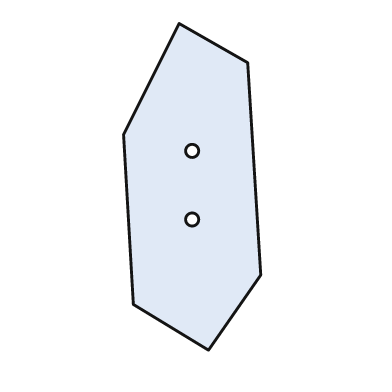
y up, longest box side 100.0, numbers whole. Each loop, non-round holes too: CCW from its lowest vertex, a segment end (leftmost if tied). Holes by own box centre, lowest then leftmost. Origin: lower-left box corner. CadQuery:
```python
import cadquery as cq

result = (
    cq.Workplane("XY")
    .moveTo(26.0, 0.0)
    .lineTo(42.0, 23.0)
    .lineTo(38.0, 88.0)
    .lineTo(17.0, 100.0)
    .lineTo(0.0, 66.0)
    .lineTo(3.0, 14.0)
    .close()
    .moveTo(21.0, 40.0)
    .circle(2.0)
    .moveTo(21.0, 61.0)
    .circle(2.0)
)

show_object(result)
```